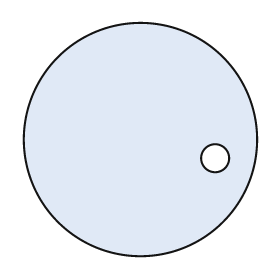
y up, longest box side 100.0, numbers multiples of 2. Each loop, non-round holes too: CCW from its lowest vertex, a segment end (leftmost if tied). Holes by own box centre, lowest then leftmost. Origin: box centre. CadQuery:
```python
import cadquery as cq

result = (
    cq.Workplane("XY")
    .moveTo(0.0, 0.0)
    .circle(50.0)
    .moveTo(32.0, -8.0)
    .circle(6.0)
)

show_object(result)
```